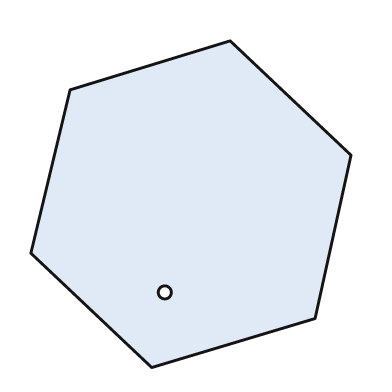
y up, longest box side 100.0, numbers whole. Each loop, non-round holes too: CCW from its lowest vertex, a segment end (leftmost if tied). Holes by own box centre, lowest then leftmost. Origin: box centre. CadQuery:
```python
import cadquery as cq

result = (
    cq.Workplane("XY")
    .moveTo(-12.0, -50.0)
    .lineTo(38.0, -35.0)
    .lineTo(49.0, 15.0)
    .lineTo(12.0, 50.0)
    .lineTo(-37.0, 35.0)
    .lineTo(-49.0, -15.0)
    .close()
    .moveTo(-8.0, -27.0)
    .circle(2.0)
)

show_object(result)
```